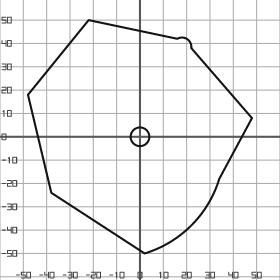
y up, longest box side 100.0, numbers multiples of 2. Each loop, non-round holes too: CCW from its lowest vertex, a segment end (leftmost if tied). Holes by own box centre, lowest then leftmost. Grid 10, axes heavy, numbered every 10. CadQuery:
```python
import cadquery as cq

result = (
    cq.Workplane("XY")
    .moveTo(2.0, -50.0)
    .threePointArc((22.0, -38.0), (34.0, -18.0))
    .lineTo(48.0, 8.0)
    .lineTo(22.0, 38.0)
    .threePointArc((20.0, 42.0), (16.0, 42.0))
    .lineTo(-22.0, 50.0)
    .lineTo(-48.0, 18.0)
    .lineTo(-38.0, -24.0)
    .close()
    .moveTo(0.0, 0.0)
    .circle(4.0)
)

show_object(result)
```